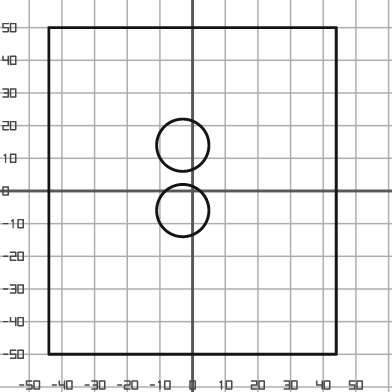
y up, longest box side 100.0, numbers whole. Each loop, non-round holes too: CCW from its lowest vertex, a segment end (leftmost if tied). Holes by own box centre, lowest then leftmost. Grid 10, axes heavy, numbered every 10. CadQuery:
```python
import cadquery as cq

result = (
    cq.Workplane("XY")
    .moveTo(-44.0, -50.0)
    .lineTo(44.0, -50.0)
    .lineTo(44.0, 50.0)
    .lineTo(-44.0, 50.0)
    .close()
    .moveTo(-3.0, -6.0)
    .circle(8.0)
    .moveTo(-3.0, 14.0)
    .circle(8.0)
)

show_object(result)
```